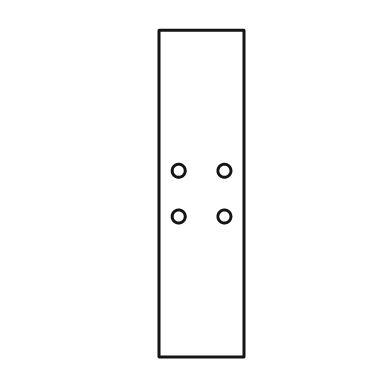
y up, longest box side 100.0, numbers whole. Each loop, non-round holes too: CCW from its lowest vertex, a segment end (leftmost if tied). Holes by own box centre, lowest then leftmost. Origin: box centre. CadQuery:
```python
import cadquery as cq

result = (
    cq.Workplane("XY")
    .moveTo(-13.0, -50.0)
    .lineTo(13.0, -50.0)
    .lineTo(13.0, 50.0)
    .lineTo(-13.0, 50.0)
    .close()
    .moveTo(-7.0, -7.0)
    .circle(2.0)
    .moveTo(7.0, -7.0)
    .circle(2.0)
    .moveTo(-7.0, 7.0)
    .circle(2.0)
    .moveTo(7.0, 7.0)
    .circle(2.0)
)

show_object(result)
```